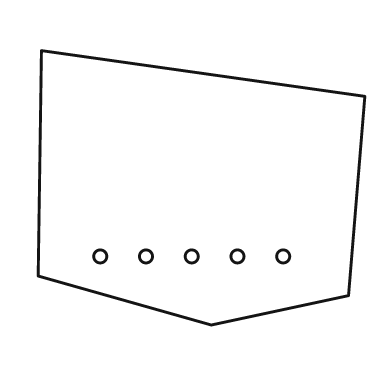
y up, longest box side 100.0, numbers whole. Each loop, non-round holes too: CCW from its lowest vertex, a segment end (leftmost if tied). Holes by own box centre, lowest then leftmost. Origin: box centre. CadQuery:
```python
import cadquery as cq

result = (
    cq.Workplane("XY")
    .moveTo(3.0, -42.0)
    .lineTo(45.0, -33.0)
    .lineTo(50.0, 28.0)
    .lineTo(-49.0, 42.0)
    .lineTo(-50.0, -27.0)
    .close()
    .moveTo(-31.0, -21.0)
    .circle(2.0)
    .moveTo(-17.0, -21.0)
    .circle(2.0)
    .moveTo(-3.0, -21.0)
    .circle(2.0)
    .moveTo(11.0, -21.0)
    .circle(2.0)
    .moveTo(25.0, -21.0)
    .circle(2.0)
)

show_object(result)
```